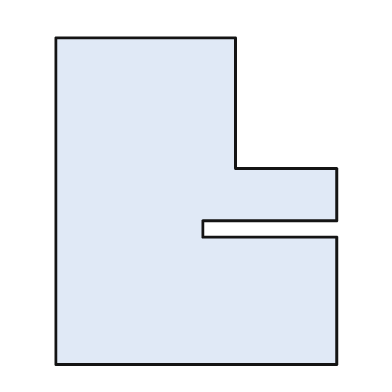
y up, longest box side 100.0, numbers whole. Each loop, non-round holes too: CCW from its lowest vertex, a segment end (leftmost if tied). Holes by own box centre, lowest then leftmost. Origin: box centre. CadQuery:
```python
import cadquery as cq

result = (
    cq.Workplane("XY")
    .moveTo(-43.0, -50.0)
    .lineTo(43.0, -50.0)
    .lineTo(43.0, -11.0)
    .lineTo(2.0, -11.0)
    .lineTo(2.0, -6.0)
    .lineTo(43.0, -6.0)
    .lineTo(43.0, 10.0)
    .lineTo(12.0, 10.0)
    .lineTo(12.0, 50.0)
    .lineTo(-43.0, 50.0)
    .close()
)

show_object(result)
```